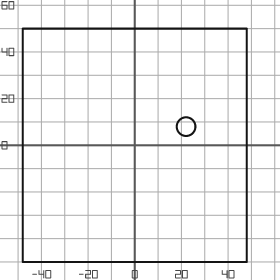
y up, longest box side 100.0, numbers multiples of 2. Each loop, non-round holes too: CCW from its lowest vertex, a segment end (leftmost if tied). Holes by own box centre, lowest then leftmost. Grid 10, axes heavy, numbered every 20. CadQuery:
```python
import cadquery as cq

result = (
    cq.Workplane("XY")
    .moveTo(-48.0, -50.0)
    .lineTo(48.0, -50.0)
    .lineTo(48.0, 50.0)
    .lineTo(-48.0, 50.0)
    .close()
    .moveTo(22.0, 8.0)
    .circle(4.0)
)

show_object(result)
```